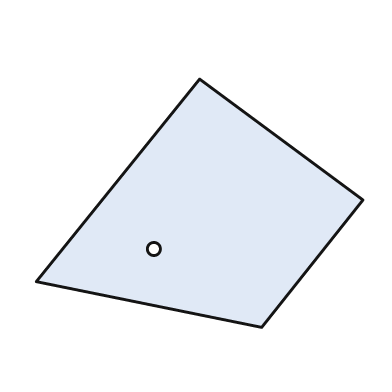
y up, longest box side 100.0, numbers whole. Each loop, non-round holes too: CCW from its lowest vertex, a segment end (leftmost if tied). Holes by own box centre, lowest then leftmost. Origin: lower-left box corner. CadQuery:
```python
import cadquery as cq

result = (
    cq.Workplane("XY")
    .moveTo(69.0, 0.0)
    .lineTo(100.0, 39.0)
    .lineTo(50.0, 76.0)
    .lineTo(0.0, 14.0)
    .close()
    .moveTo(36.0, 24.0)
    .circle(2.0)
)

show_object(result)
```